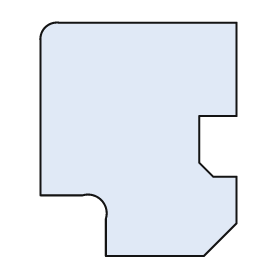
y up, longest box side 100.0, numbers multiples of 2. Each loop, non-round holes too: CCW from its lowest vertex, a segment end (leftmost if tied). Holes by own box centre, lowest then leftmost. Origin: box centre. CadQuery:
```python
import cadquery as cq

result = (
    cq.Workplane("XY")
    .moveTo(-14.0, -50.0)
    .lineTo(28.0, -50.0)
    .lineTo(42.0, -36.0)
    .lineTo(42.0, -16.0)
    .lineTo(32.0, -16.0)
    .lineTo(26.0, -10.0)
    .lineTo(26.0, 10.0)
    .lineTo(42.0, 10.0)
    .lineTo(42.0, 50.0)
    .lineTo(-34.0, 50.0)
    .threePointArc((-40.0, 48.0), (-42.0, 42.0))
    .lineTo(-42.0, -24.0)
    .lineTo(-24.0, -24.0)
    .threePointArc((-16.0, -26.0), (-14.0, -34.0))
    .close()
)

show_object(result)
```